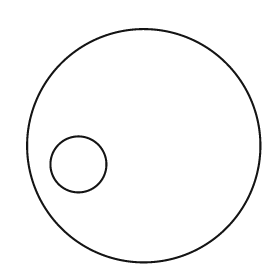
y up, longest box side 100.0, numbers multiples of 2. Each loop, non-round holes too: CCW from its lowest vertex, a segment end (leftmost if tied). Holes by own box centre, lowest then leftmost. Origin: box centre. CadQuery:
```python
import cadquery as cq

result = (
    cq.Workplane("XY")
    .moveTo(0.0, 0.0)
    .circle(50.0)
    .moveTo(-28.0, -8.0)
    .circle(12.0)
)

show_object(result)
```